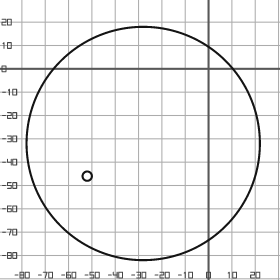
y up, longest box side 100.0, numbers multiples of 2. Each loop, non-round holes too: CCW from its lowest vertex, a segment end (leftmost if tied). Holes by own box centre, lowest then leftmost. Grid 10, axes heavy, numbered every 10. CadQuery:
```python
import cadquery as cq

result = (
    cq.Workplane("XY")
    .moveTo(-28.0, -32.0)
    .circle(50.0)
    .moveTo(-52.0, -46.0)
    .circle(2.0)
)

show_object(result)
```